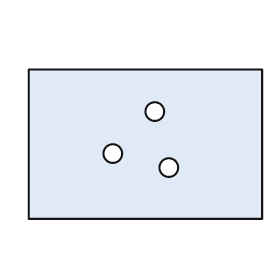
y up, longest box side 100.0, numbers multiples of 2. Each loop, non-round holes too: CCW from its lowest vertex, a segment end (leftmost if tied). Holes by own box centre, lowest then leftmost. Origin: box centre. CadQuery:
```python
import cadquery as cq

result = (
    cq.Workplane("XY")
    .moveTo(-50.0, -32.0)
    .lineTo(50.0, -32.0)
    .lineTo(50.0, 32.0)
    .lineTo(-50.0, 32.0)
    .close()
    .moveTo(10.0, -10.0)
    .circle(4.0)
    .moveTo(-14.0, -4.0)
    .circle(4.0)
    .moveTo(4.0, 14.0)
    .circle(4.0)
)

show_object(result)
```